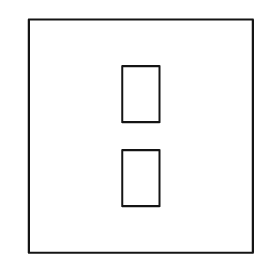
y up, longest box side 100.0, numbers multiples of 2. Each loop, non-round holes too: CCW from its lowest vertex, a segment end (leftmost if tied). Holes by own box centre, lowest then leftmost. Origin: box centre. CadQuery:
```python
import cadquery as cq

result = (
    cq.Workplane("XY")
    .moveTo(-48.0, -50.0)
    .lineTo(48.0, -50.0)
    .lineTo(48.0, 50.0)
    .lineTo(-48.0, 50.0)
    .close()
    .moveTo(-8.0, -30.0)
    .lineTo(8.0, -30.0)
    .lineTo(8.0, -6.0)
    .lineTo(-8.0, -6.0)
    .close()
    .moveTo(-8.0, 6.0)
    .lineTo(8.0, 6.0)
    .lineTo(8.0, 30.0)
    .lineTo(-8.0, 30.0)
    .close()
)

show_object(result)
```